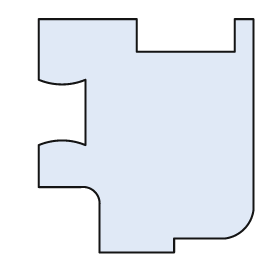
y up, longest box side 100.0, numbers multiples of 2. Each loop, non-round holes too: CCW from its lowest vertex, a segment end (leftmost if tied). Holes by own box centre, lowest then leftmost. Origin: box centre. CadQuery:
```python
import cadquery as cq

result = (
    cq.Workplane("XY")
    .moveTo(-20.0, -50.0)
    .lineTo(12.0, -50.0)
    .lineTo(12.0, -44.0)
    .lineTo(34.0, -44.0)
    .threePointArc((42.0, -40.0), (46.0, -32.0))
    .lineTo(46.0, 50.0)
    .lineTo(38.0, 50.0)
    .lineTo(38.0, 36.0)
    .lineTo(-4.0, 36.0)
    .lineTo(-4.0, 50.0)
    .lineTo(-46.0, 50.0)
    .lineTo(-46.0, 24.0)
    .threePointArc((-36.0, 22.0), (-26.0, 24.0))
    .lineTo(-26.0, -4.0)
    .threePointArc((-36.0, -2.0), (-46.0, -4.0))
    .lineTo(-46.0, -22.0)
    .lineTo(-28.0, -22.0)
    .threePointArc((-22.0, -24.0), (-20.0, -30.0))
    .close()
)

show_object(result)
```